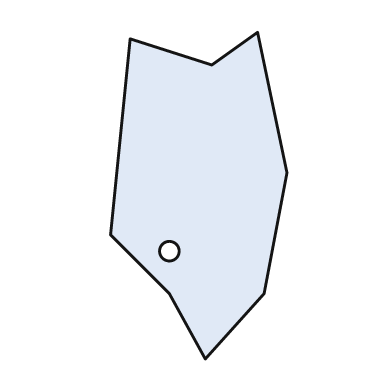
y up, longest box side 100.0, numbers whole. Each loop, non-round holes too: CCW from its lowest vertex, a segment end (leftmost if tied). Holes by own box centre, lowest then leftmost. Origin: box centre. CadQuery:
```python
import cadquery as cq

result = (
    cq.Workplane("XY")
    .moveTo(2.0, -50.0)
    .lineTo(20.0, -30.0)
    .lineTo(27.0, 7.0)
    .lineTo(18.0, 50.0)
    .lineTo(4.0, 40.0)
    .lineTo(-21.0, 48.0)
    .lineTo(-27.0, -12.0)
    .lineTo(-9.0, -30.0)
    .close()
    .moveTo(-9.0, -17.0)
    .circle(3.0)
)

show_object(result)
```